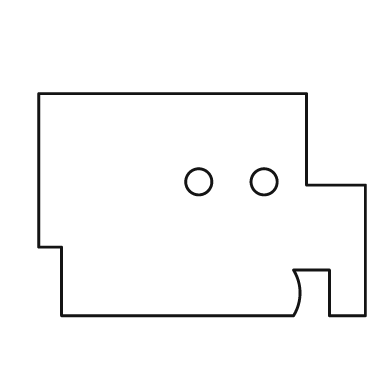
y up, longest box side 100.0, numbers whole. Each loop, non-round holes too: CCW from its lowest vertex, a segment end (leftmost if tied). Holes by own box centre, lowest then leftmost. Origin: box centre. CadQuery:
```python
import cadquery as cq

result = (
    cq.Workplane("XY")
    .moveTo(-43.0, -34.0)
    .lineTo(28.0, -34.0)
    .threePointArc((30.0, -27.0), (28.0, -20.0))
    .lineTo(39.0, -20.0)
    .lineTo(39.0, -34.0)
    .lineTo(50.0, -34.0)
    .lineTo(50.0, 6.0)
    .lineTo(32.0, 6.0)
    .lineTo(32.0, 34.0)
    .lineTo(-50.0, 34.0)
    .lineTo(-50.0, -13.0)
    .lineTo(-43.0, -13.0)
    .close()
    .moveTo(-1.0, 7.0)
    .circle(4.0)
    .moveTo(19.0, 7.0)
    .circle(4.0)
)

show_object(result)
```